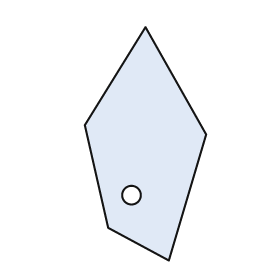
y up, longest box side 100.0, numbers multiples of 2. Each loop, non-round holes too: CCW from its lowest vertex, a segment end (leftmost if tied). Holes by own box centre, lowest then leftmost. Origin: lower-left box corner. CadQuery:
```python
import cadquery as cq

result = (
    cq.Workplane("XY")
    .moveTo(36.0, 0.0)
    .lineTo(52.0, 54.0)
    .lineTo(26.0, 100.0)
    .lineTo(0.0, 58.0)
    .lineTo(10.0, 14.0)
    .close()
    .moveTo(20.0, 28.0)
    .circle(4.0)
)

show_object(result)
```